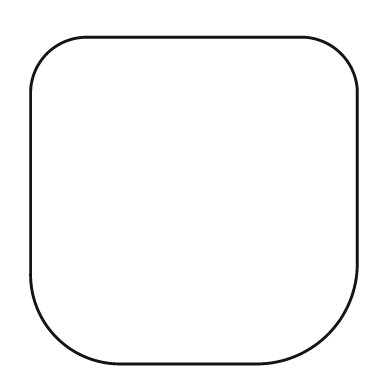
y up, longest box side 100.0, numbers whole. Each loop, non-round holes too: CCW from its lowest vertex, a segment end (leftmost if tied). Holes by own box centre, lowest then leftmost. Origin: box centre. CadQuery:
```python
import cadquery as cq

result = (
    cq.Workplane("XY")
    .moveTo(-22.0, -50.0)
    .lineTo(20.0, -50.0)
    .threePointArc((41.0, -41.0), (50.0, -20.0))
    .lineTo(50.0, 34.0)
    .threePointArc((45.0, 45.0), (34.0, 50.0))
    .lineTo(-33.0, 50.0)
    .threePointArc((-45.0, 45.0), (-50.0, 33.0))
    .lineTo(-50.0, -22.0)
    .threePointArc((-42.0, -42.0), (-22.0, -50.0))
    .close()
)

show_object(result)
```